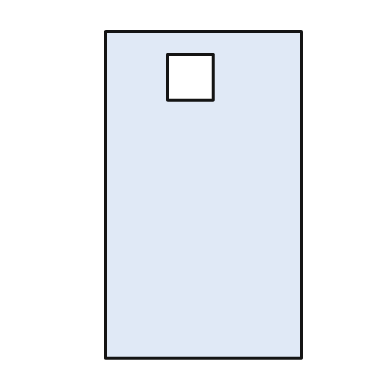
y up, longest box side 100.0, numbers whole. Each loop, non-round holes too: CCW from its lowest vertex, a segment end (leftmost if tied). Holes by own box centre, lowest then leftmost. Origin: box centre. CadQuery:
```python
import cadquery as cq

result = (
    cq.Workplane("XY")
    .moveTo(-30.0, -50.0)
    .lineTo(30.0, -50.0)
    .lineTo(30.0, 50.0)
    .lineTo(-30.0, 50.0)
    .close()
    .moveTo(-11.0, 29.0)
    .lineTo(3.0, 29.0)
    .lineTo(3.0, 43.0)
    .lineTo(-11.0, 43.0)
    .close()
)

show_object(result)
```